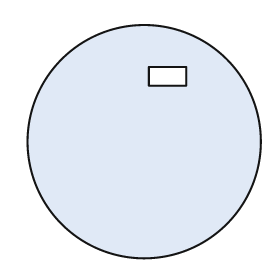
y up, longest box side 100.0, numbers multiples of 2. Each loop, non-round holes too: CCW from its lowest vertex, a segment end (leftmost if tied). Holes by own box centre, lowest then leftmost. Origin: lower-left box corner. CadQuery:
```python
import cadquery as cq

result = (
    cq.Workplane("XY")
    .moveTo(50.0, 50.0)
    .circle(50.0)
    .moveTo(52.0, 74.0)
    .lineTo(68.0, 74.0)
    .lineTo(68.0, 82.0)
    .lineTo(52.0, 82.0)
    .close()
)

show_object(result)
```